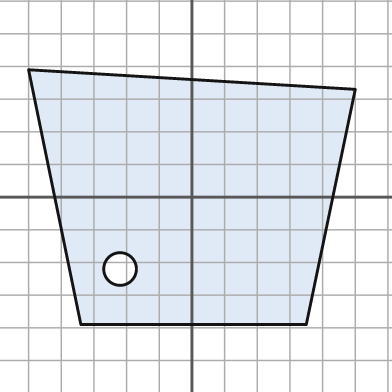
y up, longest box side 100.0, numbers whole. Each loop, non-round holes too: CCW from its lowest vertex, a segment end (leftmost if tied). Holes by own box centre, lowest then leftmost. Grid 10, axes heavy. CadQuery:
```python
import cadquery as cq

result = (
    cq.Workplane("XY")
    .moveTo(-34.0, -39.0)
    .lineTo(35.0, -39.0)
    .lineTo(50.0, 33.0)
    .lineTo(-50.0, 39.0)
    .close()
    .moveTo(-22.0, -22.0)
    .circle(5.0)
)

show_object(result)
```